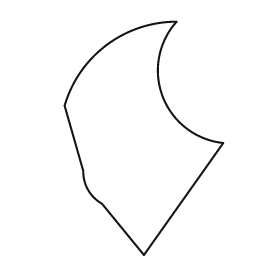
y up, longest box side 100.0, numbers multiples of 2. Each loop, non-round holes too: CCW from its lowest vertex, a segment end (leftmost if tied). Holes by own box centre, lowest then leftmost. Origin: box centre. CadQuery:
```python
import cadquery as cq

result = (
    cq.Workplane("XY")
    .moveTo(0.0, -50.0)
    .lineTo(34.0, -2.0)
    .threePointArc((8.0, 18.0), (14.0, 50.0))
    .threePointArc((-16.0, 40.0), (-34.0, 14.0))
    .lineTo(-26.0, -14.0)
    .threePointArc((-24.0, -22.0), (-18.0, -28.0))
    .close()
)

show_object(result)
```